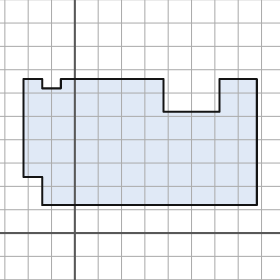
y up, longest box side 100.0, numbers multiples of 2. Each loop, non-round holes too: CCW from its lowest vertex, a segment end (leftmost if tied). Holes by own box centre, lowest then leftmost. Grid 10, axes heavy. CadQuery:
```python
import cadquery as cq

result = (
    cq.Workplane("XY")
    .moveTo(-14.0, 12.0)
    .lineTo(78.0, 12.0)
    .lineTo(78.0, 66.0)
    .lineTo(62.0, 66.0)
    .lineTo(62.0, 52.0)
    .lineTo(38.0, 52.0)
    .lineTo(38.0, 66.0)
    .lineTo(-6.0, 66.0)
    .lineTo(-6.0, 62.0)
    .lineTo(-14.0, 62.0)
    .lineTo(-14.0, 66.0)
    .lineTo(-22.0, 66.0)
    .lineTo(-22.0, 24.0)
    .lineTo(-14.0, 24.0)
    .close()
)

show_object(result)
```